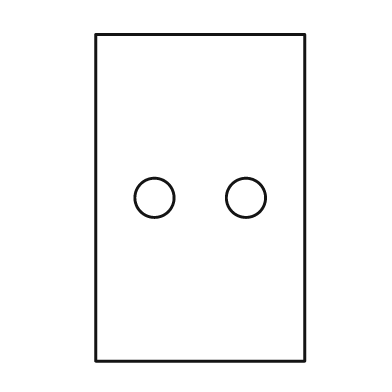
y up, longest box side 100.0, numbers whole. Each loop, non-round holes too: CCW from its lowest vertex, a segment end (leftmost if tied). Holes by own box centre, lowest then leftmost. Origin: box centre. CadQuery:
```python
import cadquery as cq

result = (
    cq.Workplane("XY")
    .moveTo(-32.0, -50.0)
    .lineTo(32.0, -50.0)
    .lineTo(32.0, 50.0)
    .lineTo(-32.0, 50.0)
    .close()
    .moveTo(-14.0, 0.0)
    .circle(6.0)
    .moveTo(14.0, 0.0)
    .circle(6.0)
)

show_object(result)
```